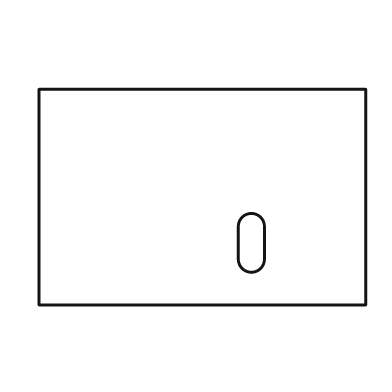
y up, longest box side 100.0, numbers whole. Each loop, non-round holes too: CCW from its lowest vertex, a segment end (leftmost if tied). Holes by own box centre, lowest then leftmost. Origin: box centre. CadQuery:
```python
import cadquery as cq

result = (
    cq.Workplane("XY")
    .moveTo(-50.0, -33.0)
    .lineTo(50.0, -33.0)
    .lineTo(50.0, 33.0)
    .lineTo(-50.0, 33.0)
    .close()
    .moveTo(11.0, -19.0)
    .threePointArc((15.0, -23.0), (19.0, -19.0))
    .lineTo(19.0, -9.0)
    .threePointArc((15.0, -5.0), (11.0, -9.0))
    .close()
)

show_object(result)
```